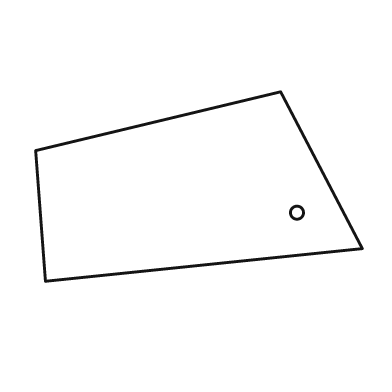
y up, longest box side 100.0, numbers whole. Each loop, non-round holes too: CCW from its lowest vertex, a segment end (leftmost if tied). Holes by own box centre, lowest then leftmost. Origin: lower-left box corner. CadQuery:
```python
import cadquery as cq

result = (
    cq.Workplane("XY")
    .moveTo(3.0, 0.0)
    .lineTo(100.0, 10.0)
    .lineTo(75.0, 58.0)
    .lineTo(0.0, 40.0)
    .close()
    .moveTo(80.0, 21.0)
    .circle(2.0)
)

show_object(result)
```